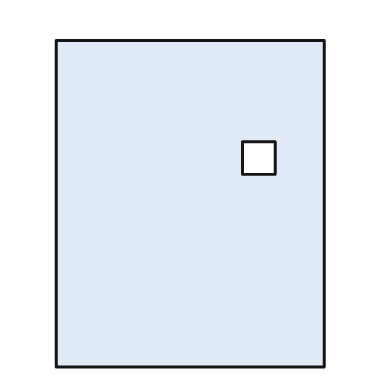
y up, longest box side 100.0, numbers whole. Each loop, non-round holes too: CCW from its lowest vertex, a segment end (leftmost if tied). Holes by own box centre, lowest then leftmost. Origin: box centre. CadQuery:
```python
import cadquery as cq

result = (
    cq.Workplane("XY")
    .moveTo(-41.0, -50.0)
    .lineTo(41.0, -50.0)
    .lineTo(41.0, 50.0)
    .lineTo(-41.0, 50.0)
    .close()
    .moveTo(16.0, 9.0)
    .lineTo(26.0, 9.0)
    .lineTo(26.0, 19.0)
    .lineTo(16.0, 19.0)
    .close()
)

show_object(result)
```